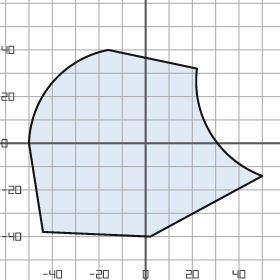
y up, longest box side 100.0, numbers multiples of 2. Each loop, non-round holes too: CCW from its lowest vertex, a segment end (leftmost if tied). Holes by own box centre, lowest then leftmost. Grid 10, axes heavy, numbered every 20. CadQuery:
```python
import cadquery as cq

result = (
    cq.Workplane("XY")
    .moveTo(2.0, -40.0)
    .lineTo(50.0, -14.0)
    .threePointArc((28.0, 4.0), (22.0, 32.0))
    .lineTo(-16.0, 40.0)
    .threePointArc((-40.0, 26.0), (-50.0, 0.0))
    .lineTo(-44.0, -38.0)
    .close()
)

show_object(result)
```